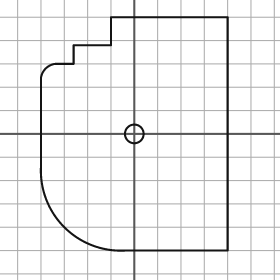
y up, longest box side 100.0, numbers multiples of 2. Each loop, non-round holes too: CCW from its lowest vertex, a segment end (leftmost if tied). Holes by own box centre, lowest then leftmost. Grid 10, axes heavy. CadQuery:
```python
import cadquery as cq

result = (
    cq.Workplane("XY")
    .moveTo(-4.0, -50.0)
    .lineTo(40.0, -50.0)
    .lineTo(40.0, 50.0)
    .lineTo(-10.0, 50.0)
    .lineTo(-10.0, 38.0)
    .lineTo(-26.0, 38.0)
    .lineTo(-26.0, 30.0)
    .lineTo(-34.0, 30.0)
    .threePointArc((-38.0, 28.0), (-40.0, 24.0))
    .lineTo(-40.0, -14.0)
    .threePointArc((-30.0, -40.0), (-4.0, -50.0))
    .close()
    .moveTo(0.0, 0.0)
    .circle(4.0)
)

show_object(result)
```